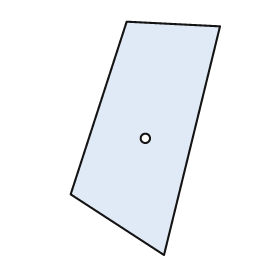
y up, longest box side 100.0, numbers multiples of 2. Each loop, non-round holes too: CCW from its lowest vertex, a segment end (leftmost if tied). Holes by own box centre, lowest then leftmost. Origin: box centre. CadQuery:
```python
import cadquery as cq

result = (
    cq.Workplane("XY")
    .moveTo(8.0, -50.0)
    .lineTo(32.0, 48.0)
    .lineTo(-8.0, 50.0)
    .lineTo(-32.0, -24.0)
    .close()
    .moveTo(0.0, 0.0)
    .circle(2.0)
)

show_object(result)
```